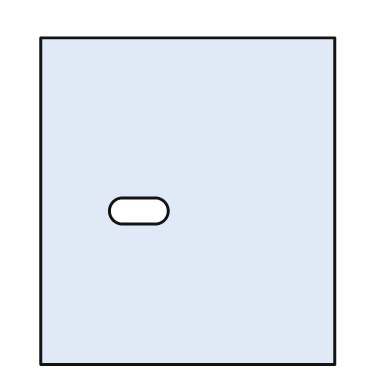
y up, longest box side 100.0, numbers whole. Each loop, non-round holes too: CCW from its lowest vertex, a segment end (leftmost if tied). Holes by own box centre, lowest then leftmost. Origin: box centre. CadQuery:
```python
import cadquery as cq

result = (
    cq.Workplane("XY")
    .moveTo(-45.0, -50.0)
    .lineTo(45.0, -50.0)
    .lineTo(45.0, 50.0)
    .lineTo(-45.0, 50.0)
    .close()
    .moveTo(-20.0, -7.0)
    .lineTo(-10.0, -7.0)
    .threePointArc((-6.0, -3.0), (-10.0, 1.0))
    .lineTo(-20.0, 1.0)
    .threePointArc((-24.0, -3.0), (-20.0, -7.0))
    .close()
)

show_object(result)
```